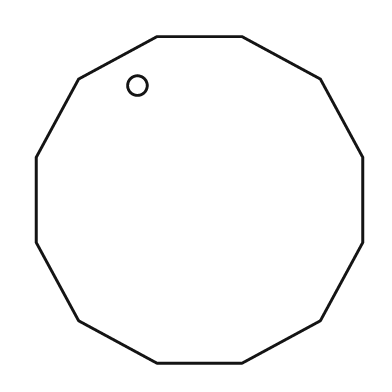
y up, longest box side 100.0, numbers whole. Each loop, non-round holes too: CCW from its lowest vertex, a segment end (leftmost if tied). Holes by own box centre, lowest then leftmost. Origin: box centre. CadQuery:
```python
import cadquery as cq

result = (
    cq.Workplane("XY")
    .moveTo(-13.0, -50.0)
    .lineTo(13.0, -50.0)
    .lineTo(37.0, -37.0)
    .lineTo(50.0, -13.0)
    .lineTo(50.0, 13.0)
    .lineTo(37.0, 37.0)
    .lineTo(13.0, 50.0)
    .lineTo(-13.0, 50.0)
    .lineTo(-37.0, 37.0)
    .lineTo(-50.0, 13.0)
    .lineTo(-50.0, -13.0)
    .lineTo(-37.0, -37.0)
    .close()
    .moveTo(-19.0, 35.0)
    .circle(3.0)
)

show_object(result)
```